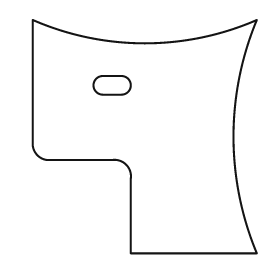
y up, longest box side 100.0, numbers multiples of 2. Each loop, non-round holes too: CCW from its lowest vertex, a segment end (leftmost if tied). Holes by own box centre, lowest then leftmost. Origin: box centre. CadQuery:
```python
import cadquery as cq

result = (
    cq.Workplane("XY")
    .moveTo(-6.0, -50.0)
    .lineTo(48.0, -50.0)
    .threePointArc((38.0, 0.0), (48.0, 50.0))
    .threePointArc((0.0, 40.0), (-48.0, 50.0))
    .lineTo(-48.0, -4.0)
    .threePointArc((-46.0, -8.0), (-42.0, -10.0))
    .lineTo(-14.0, -10.0)
    .threePointArc((-8.0, -12.0), (-6.0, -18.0))
    .close()
    .moveTo(-18.0, 18.0)
    .lineTo(-10.0, 18.0)
    .threePointArc((-6.0, 22.0), (-10.0, 26.0))
    .lineTo(-18.0, 26.0)
    .threePointArc((-22.0, 22.0), (-18.0, 18.0))
    .close()
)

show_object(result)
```